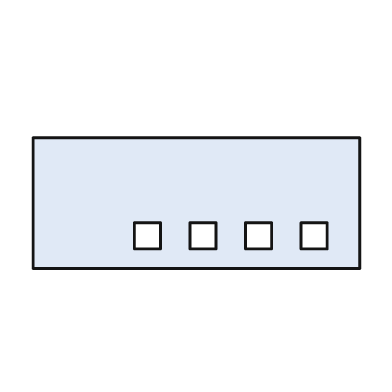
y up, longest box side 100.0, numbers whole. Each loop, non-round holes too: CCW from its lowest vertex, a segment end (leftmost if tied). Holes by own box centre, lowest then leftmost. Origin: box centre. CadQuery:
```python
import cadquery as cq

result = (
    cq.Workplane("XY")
    .moveTo(-50.0, -20.0)
    .lineTo(50.0, -20.0)
    .lineTo(50.0, 20.0)
    .lineTo(-50.0, 20.0)
    .close()
    .moveTo(-19.0, -14.0)
    .lineTo(-11.0, -14.0)
    .lineTo(-11.0, -6.0)
    .lineTo(-19.0, -6.0)
    .close()
    .moveTo(-2.0, -14.0)
    .lineTo(6.0, -14.0)
    .lineTo(6.0, -6.0)
    .lineTo(-2.0, -6.0)
    .close()
    .moveTo(15.0, -14.0)
    .lineTo(23.0, -14.0)
    .lineTo(23.0, -6.0)
    .lineTo(15.0, -6.0)
    .close()
    .moveTo(32.0, -14.0)
    .lineTo(40.0, -14.0)
    .lineTo(40.0, -6.0)
    .lineTo(32.0, -6.0)
    .close()
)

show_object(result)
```